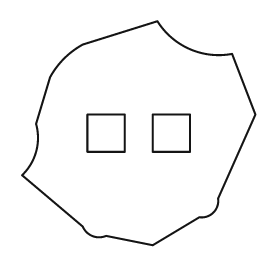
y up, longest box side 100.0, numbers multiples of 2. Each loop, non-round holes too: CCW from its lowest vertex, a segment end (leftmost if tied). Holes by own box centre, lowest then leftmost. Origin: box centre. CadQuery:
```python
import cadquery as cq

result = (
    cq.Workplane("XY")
    .moveTo(6.0, -48.0)
    .lineTo(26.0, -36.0)
    .threePointArc((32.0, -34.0), (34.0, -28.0))
    .lineTo(50.0, 8.0)
    .lineTo(40.0, 34.0)
    .threePointArc((22.0, 36.0), (8.0, 48.0))
    .lineTo(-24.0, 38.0)
    .threePointArc((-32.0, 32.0), (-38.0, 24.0))
    .lineTo(-44.0, 4.0)
    .threePointArc((-44.0, -8.0), (-50.0, -18.0))
    .lineTo(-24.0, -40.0)
    .threePointArc((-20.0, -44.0), (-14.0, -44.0))
    .close()
    .moveTo(-22.0, -8.0)
    .lineTo(-6.0, -8.0)
    .lineTo(-6.0, 8.0)
    .lineTo(-22.0, 8.0)
    .close()
    .moveTo(6.0, -8.0)
    .lineTo(22.0, -8.0)
    .lineTo(22.0, 8.0)
    .lineTo(6.0, 8.0)
    .close()
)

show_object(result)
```